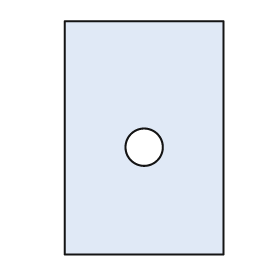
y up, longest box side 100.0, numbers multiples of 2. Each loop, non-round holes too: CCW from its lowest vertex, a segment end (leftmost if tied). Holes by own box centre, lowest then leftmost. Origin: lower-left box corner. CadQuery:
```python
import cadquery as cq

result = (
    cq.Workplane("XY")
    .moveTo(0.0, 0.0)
    .lineTo(68.0, 0.0)
    .lineTo(68.0, 100.0)
    .lineTo(0.0, 100.0)
    .close()
    .moveTo(34.0, 46.0)
    .circle(8.0)
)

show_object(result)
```